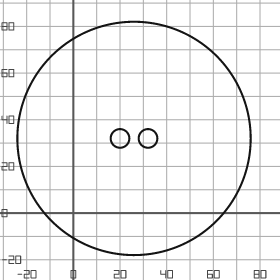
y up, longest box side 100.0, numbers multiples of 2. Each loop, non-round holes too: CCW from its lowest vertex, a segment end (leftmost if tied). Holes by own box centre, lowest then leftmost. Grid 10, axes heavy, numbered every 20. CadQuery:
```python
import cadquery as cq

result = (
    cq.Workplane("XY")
    .moveTo(26.0, 32.0)
    .circle(50.0)
    .moveTo(20.0, 32.0)
    .circle(4.0)
    .moveTo(32.0, 32.0)
    .circle(4.0)
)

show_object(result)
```